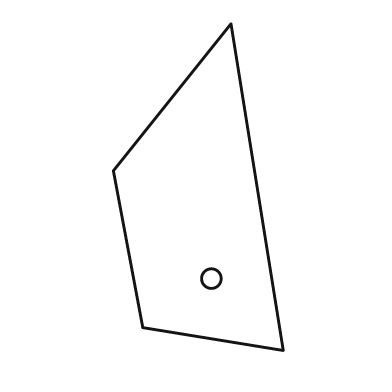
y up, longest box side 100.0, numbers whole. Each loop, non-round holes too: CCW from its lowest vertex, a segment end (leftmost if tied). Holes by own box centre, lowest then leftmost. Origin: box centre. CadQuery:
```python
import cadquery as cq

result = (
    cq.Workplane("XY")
    .moveTo(26.0, -50.0)
    .lineTo(10.0, 50.0)
    .lineTo(-26.0, 5.0)
    .lineTo(-17.0, -43.0)
    .close()
    .moveTo(4.0, -28.0)
    .circle(3.0)
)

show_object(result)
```